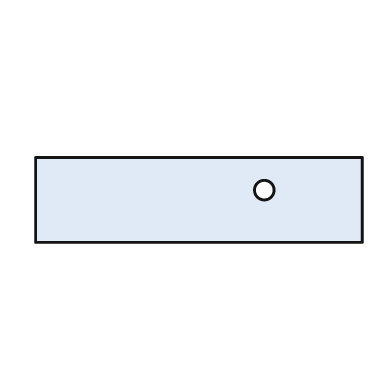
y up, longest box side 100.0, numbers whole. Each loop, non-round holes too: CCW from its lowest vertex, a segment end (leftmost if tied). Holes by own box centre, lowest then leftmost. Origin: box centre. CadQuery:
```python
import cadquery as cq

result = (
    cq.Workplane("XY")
    .moveTo(-50.0, -13.0)
    .lineTo(50.0, -13.0)
    .lineTo(50.0, 13.0)
    .lineTo(-50.0, 13.0)
    .close()
    .moveTo(20.0, 3.0)
    .circle(3.0)
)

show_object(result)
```